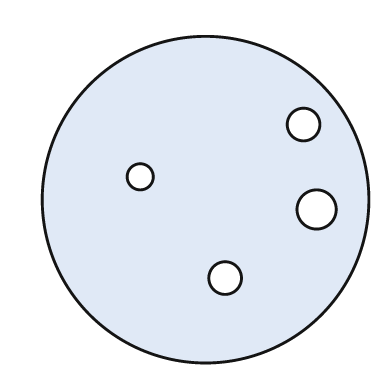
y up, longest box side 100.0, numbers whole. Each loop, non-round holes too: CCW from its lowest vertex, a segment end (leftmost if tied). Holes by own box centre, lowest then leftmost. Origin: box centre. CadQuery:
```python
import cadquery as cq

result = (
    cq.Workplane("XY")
    .moveTo(0.0, 0.0)
    .circle(50.0)
    .moveTo(6.0, -24.0)
    .circle(5.0)
    .moveTo(34.0, -3.0)
    .circle(6.0)
    .moveTo(-20.0, 7.0)
    .circle(4.0)
    .moveTo(30.0, 23.0)
    .circle(5.0)
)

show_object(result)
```